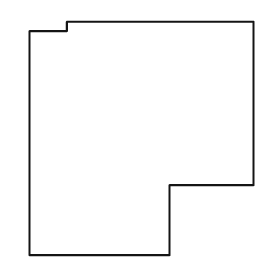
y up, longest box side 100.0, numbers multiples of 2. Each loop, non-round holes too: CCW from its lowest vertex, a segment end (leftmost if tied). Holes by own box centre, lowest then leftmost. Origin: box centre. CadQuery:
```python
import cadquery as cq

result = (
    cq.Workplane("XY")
    .moveTo(-48.0, -50.0)
    .lineTo(12.0, -50.0)
    .lineTo(12.0, -20.0)
    .lineTo(48.0, -20.0)
    .lineTo(48.0, 50.0)
    .lineTo(-32.0, 50.0)
    .lineTo(-32.0, 46.0)
    .lineTo(-48.0, 46.0)
    .close()
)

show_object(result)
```